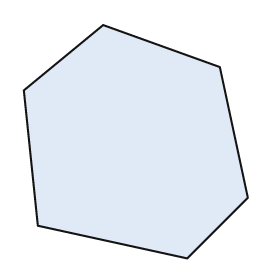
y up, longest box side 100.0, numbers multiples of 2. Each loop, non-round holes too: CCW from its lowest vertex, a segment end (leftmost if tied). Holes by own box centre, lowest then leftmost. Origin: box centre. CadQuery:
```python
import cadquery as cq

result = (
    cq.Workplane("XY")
    .moveTo(22.0, -50.0)
    .lineTo(48.0, -24.0)
    .lineTo(36.0, 32.0)
    .lineTo(-14.0, 50.0)
    .lineTo(-48.0, 22.0)
    .lineTo(-42.0, -36.0)
    .close()
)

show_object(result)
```